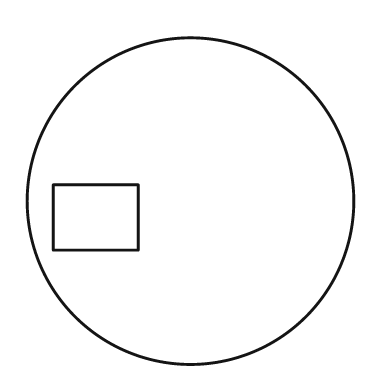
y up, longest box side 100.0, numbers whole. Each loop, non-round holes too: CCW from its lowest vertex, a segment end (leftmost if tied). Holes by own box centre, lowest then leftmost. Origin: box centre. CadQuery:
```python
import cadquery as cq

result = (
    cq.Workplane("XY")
    .moveTo(0.0, 0.0)
    .circle(50.0)
    .moveTo(-42.0, -15.0)
    .lineTo(-16.0, -15.0)
    .lineTo(-16.0, 5.0)
    .lineTo(-42.0, 5.0)
    .close()
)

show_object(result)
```